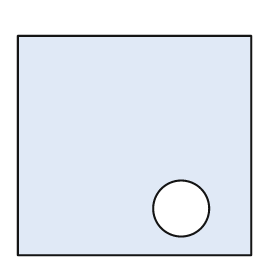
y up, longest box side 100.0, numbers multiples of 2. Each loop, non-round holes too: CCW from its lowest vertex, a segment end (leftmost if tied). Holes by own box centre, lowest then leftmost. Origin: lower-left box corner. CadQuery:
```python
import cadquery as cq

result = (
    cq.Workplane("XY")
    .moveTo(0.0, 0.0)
    .lineTo(100.0, 0.0)
    .lineTo(100.0, 94.0)
    .lineTo(0.0, 94.0)
    .close()
    .moveTo(70.0, 20.0)
    .circle(12.0)
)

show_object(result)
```